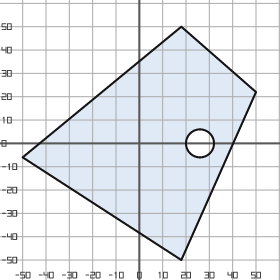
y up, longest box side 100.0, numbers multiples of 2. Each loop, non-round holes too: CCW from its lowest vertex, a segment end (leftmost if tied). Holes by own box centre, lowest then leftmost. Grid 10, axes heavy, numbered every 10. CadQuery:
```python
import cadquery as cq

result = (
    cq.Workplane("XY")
    .moveTo(18.0, -50.0)
    .lineTo(50.0, 22.0)
    .lineTo(18.0, 50.0)
    .lineTo(-50.0, -6.0)
    .close()
    .moveTo(26.0, 0.0)
    .circle(6.0)
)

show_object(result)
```